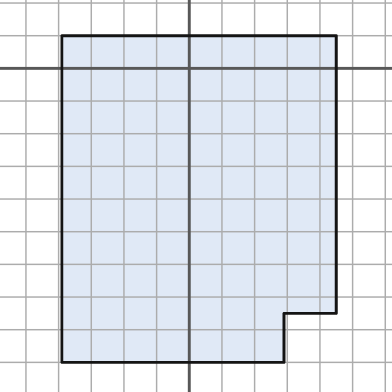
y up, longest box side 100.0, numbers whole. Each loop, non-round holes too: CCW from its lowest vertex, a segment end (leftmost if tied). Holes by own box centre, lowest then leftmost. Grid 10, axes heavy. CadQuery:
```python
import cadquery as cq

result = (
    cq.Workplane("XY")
    .moveTo(-39.0, -90.0)
    .lineTo(29.0, -90.0)
    .lineTo(29.0, -75.0)
    .lineTo(45.0, -75.0)
    .lineTo(45.0, 10.0)
    .lineTo(-39.0, 10.0)
    .close()
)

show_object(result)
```